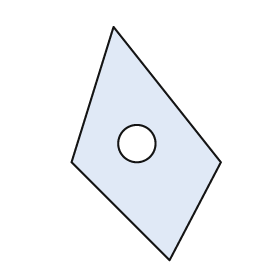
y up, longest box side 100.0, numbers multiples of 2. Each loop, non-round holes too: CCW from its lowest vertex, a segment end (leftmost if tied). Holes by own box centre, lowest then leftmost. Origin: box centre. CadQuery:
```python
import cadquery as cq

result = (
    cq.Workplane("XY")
    .moveTo(10.0, -50.0)
    .lineTo(32.0, -8.0)
    .lineTo(-14.0, 50.0)
    .lineTo(-32.0, -8.0)
    .close()
    .moveTo(-4.0, 0.0)
    .circle(8.0)
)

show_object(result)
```